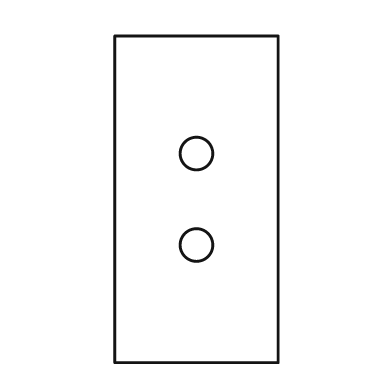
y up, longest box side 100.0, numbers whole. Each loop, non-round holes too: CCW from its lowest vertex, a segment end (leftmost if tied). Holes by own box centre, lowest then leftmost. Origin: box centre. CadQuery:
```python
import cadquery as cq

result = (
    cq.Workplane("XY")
    .moveTo(-25.0, -50.0)
    .lineTo(25.0, -50.0)
    .lineTo(25.0, 50.0)
    .lineTo(-25.0, 50.0)
    .close()
    .moveTo(0.0, -14.0)
    .circle(5.0)
    .moveTo(0.0, 14.0)
    .circle(5.0)
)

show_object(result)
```